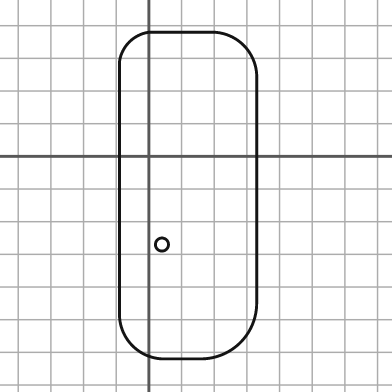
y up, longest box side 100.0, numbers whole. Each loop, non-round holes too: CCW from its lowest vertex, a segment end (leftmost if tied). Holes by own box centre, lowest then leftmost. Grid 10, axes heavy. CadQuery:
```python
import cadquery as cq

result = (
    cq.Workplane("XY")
    .moveTo(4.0, -62.0)
    .lineTo(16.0, -62.0)
    .threePointArc((28.0, -57.0), (33.0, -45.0))
    .lineTo(33.0, 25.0)
    .threePointArc((29.0, 34.0), (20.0, 38.0))
    .lineTo(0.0, 38.0)
    .threePointArc((-6.0, 35.0), (-9.0, 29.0))
    .lineTo(-9.0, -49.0)
    .threePointArc((-5.0, -58.0), (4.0, -62.0))
    .close()
    .moveTo(4.0, -27.0)
    .circle(2.0)
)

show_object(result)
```